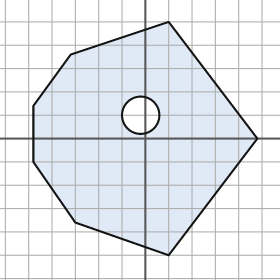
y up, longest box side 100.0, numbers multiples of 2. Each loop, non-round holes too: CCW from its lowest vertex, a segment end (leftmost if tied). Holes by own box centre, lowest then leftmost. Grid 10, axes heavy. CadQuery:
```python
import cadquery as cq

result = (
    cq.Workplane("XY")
    .moveTo(10.0, -50.0)
    .lineTo(48.0, 0.0)
    .lineTo(10.0, 50.0)
    .lineTo(-32.0, 36.0)
    .lineTo(-48.0, 14.0)
    .lineTo(-48.0, -10.0)
    .lineTo(-30.0, -36.0)
    .close()
    .moveTo(-2.0, 10.0)
    .circle(8.0)
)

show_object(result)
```